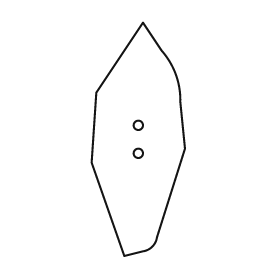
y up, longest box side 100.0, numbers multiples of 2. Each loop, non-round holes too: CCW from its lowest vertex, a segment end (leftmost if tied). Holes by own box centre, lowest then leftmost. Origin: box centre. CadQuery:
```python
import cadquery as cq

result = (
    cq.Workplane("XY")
    .moveTo(-6.0, -50.0)
    .lineTo(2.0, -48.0)
    .threePointArc((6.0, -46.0), (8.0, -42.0))
    .lineTo(20.0, -4.0)
    .lineTo(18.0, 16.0)
    .threePointArc((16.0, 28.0), (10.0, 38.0))
    .lineTo(2.0, 50.0)
    .lineTo(-18.0, 20.0)
    .lineTo(-20.0, -10.0)
    .close()
    .moveTo(0.0, -6.0)
    .circle(2.0)
    .moveTo(0.0, 6.0)
    .circle(2.0)
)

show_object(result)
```